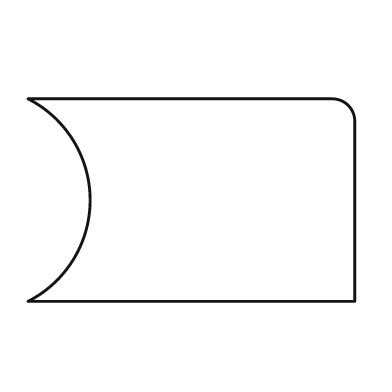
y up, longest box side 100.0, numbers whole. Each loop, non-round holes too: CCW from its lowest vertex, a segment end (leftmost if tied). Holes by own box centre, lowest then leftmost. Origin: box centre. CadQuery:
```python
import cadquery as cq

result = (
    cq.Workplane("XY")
    .moveTo(-50.0, -31.0)
    .lineTo(50.0, -31.0)
    .lineTo(50.0, 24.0)
    .threePointArc((48.0, 29.0), (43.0, 31.0))
    .lineTo(-50.0, 31.0)
    .threePointArc((-31.0, 0.0), (-50.0, -31.0))
    .close()
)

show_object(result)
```